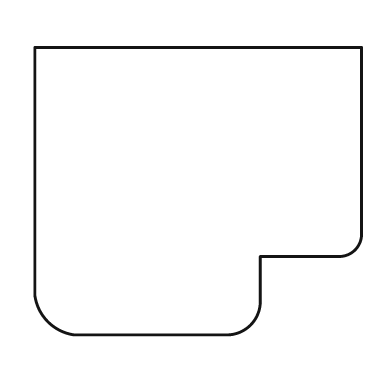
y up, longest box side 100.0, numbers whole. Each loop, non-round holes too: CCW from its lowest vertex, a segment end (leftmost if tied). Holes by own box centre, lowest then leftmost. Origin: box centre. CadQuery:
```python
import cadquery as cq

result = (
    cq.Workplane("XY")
    .moveTo(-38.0, -44.0)
    .lineTo(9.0, -44.0)
    .threePointArc((16.0, -41.0), (19.0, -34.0))
    .lineTo(19.0, -20.0)
    .lineTo(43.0, -20.0)
    .threePointArc((48.0, -18.0), (50.0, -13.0))
    .lineTo(50.0, 44.0)
    .lineTo(-50.0, 44.0)
    .lineTo(-50.0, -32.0)
    .threePointArc((-46.0, -40.0), (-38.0, -44.0))
    .close()
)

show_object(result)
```